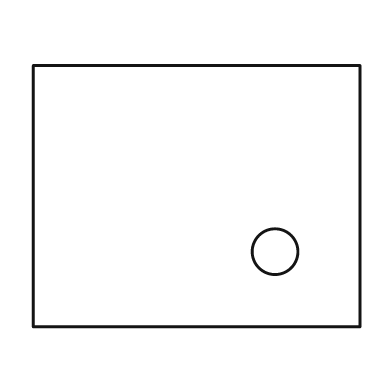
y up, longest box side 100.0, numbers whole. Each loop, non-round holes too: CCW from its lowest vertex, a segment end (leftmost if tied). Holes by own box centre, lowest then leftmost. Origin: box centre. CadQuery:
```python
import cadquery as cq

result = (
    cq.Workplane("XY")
    .moveTo(-50.0, -40.0)
    .lineTo(50.0, -40.0)
    .lineTo(50.0, 40.0)
    .lineTo(-50.0, 40.0)
    .close()
    .moveTo(24.0, -17.0)
    .circle(7.0)
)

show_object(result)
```